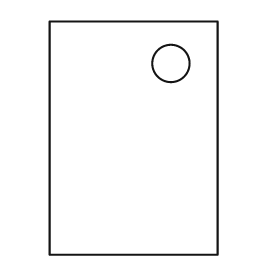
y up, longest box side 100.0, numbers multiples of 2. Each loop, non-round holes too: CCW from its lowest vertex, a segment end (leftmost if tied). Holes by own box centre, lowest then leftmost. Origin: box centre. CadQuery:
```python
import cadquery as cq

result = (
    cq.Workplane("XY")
    .moveTo(-36.0, -50.0)
    .lineTo(36.0, -50.0)
    .lineTo(36.0, 50.0)
    .lineTo(-36.0, 50.0)
    .close()
    .moveTo(16.0, 32.0)
    .circle(8.0)
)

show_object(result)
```